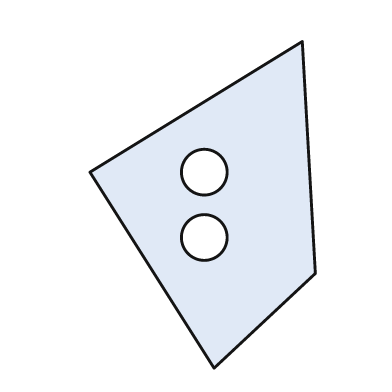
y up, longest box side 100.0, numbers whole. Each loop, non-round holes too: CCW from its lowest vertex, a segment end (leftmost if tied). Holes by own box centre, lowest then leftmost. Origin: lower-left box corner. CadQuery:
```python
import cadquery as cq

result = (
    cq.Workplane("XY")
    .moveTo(38.0, 0.0)
    .lineTo(69.0, 29.0)
    .lineTo(65.0, 100.0)
    .lineTo(0.0, 60.0)
    .close()
    .moveTo(35.0, 40.0)
    .circle(7.0)
    .moveTo(35.0, 60.0)
    .circle(7.0)
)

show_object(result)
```